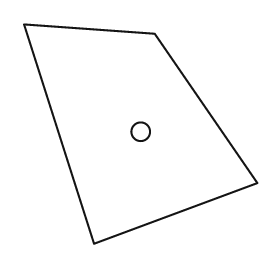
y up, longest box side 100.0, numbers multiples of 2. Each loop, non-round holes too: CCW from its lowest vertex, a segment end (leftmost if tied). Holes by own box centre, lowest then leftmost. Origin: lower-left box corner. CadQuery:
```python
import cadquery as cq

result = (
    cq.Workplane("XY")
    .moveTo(30.0, 0.0)
    .lineTo(100.0, 26.0)
    .lineTo(56.0, 90.0)
    .lineTo(0.0, 94.0)
    .close()
    .moveTo(50.0, 48.0)
    .circle(4.0)
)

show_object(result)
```